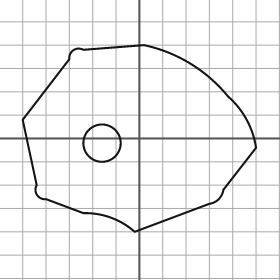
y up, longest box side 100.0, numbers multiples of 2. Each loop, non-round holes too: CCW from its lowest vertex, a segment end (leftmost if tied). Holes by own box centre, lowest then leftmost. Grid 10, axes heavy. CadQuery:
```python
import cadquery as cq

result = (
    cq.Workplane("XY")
    .moveTo(-2.0, -40.0)
    .lineTo(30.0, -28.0)
    .threePointArc((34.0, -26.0), (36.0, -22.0))
    .lineTo(50.0, -4.0)
    .threePointArc((46.0, 8.0), (38.0, 18.0))
    .threePointArc((22.0, 32.0), (2.0, 40.0))
    .lineTo(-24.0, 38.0)
    .threePointArc((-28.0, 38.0), (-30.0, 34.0))
    .lineTo(-50.0, 8.0)
    .lineTo(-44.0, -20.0)
    .threePointArc((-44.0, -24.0), (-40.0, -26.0))
    .lineTo(-24.0, -32.0)
    .threePointArc((-12.0, -34.0), (-2.0, -40.0))
    .close()
    .moveTo(-16.0, -2.0)
    .circle(8.0)
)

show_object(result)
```